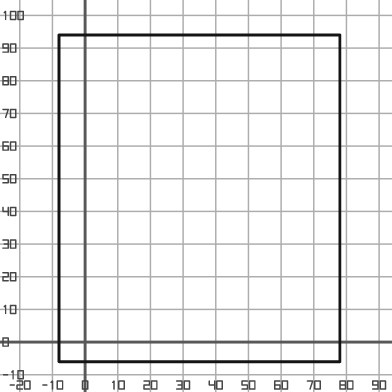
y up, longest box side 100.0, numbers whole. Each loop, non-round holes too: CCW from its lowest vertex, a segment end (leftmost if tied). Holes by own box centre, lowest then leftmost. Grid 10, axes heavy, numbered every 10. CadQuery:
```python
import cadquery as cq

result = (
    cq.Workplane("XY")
    .moveTo(-8.0, -6.0)
    .lineTo(78.0, -6.0)
    .lineTo(78.0, 94.0)
    .lineTo(-8.0, 94.0)
    .close()
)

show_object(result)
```